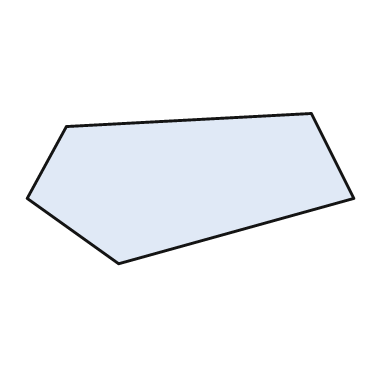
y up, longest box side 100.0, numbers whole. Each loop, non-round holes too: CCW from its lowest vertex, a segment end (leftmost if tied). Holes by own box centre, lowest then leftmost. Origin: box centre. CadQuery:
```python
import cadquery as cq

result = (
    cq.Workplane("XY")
    .moveTo(-22.0, -23.0)
    .lineTo(50.0, -3.0)
    .lineTo(37.0, 23.0)
    .lineTo(-38.0, 19.0)
    .lineTo(-50.0, -3.0)
    .close()
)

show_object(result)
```